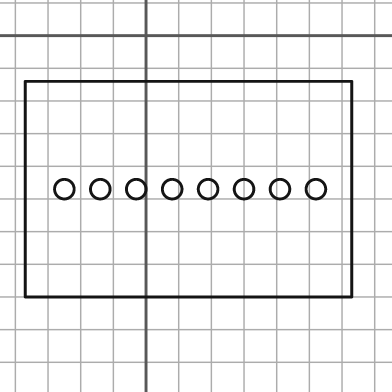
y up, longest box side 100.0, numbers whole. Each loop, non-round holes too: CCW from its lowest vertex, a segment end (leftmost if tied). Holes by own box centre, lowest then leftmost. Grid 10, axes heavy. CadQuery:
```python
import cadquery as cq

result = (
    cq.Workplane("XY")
    .moveTo(-37.0, -80.0)
    .lineTo(63.0, -80.0)
    .lineTo(63.0, -14.0)
    .lineTo(-37.0, -14.0)
    .close()
    .moveTo(-25.0, -47.0)
    .circle(3.0)
    .moveTo(-14.0, -47.0)
    .circle(3.0)
    .moveTo(-3.0, -47.0)
    .circle(3.0)
    .moveTo(8.0, -47.0)
    .circle(3.0)
    .moveTo(19.0, -47.0)
    .circle(3.0)
    .moveTo(30.0, -47.0)
    .circle(3.0)
    .moveTo(41.0, -47.0)
    .circle(3.0)
    .moveTo(52.0, -47.0)
    .circle(3.0)
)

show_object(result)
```